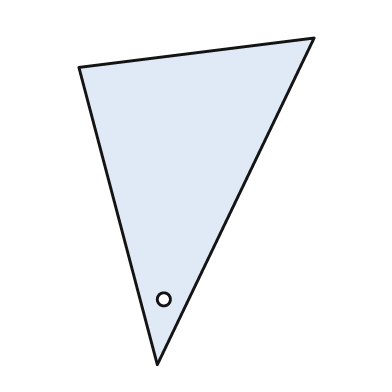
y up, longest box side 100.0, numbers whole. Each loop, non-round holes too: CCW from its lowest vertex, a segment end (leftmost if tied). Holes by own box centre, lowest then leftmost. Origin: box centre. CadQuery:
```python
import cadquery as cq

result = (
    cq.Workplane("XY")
    .moveTo(-12.0, -50.0)
    .lineTo(36.0, 50.0)
    .lineTo(-36.0, 41.0)
    .close()
    .moveTo(-10.0, -30.0)
    .circle(2.0)
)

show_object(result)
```